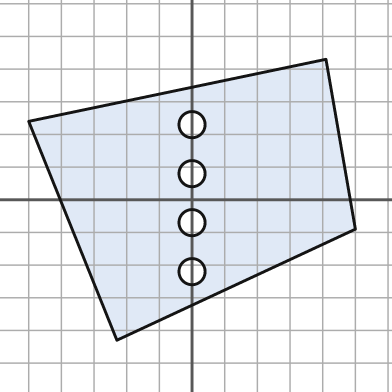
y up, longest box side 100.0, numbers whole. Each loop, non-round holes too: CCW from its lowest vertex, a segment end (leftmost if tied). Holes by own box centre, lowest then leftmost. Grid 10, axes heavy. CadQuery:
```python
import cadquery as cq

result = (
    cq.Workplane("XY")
    .moveTo(-23.0, -43.0)
    .lineTo(50.0, -9.0)
    .lineTo(41.0, 43.0)
    .lineTo(-50.0, 24.0)
    .close()
    .moveTo(0.0, -22.0)
    .circle(4.0)
    .moveTo(0.0, -7.0)
    .circle(4.0)
    .moveTo(0.0, 8.0)
    .circle(4.0)
    .moveTo(0.0, 23.0)
    .circle(4.0)
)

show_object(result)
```